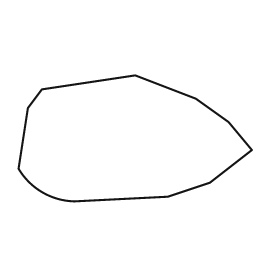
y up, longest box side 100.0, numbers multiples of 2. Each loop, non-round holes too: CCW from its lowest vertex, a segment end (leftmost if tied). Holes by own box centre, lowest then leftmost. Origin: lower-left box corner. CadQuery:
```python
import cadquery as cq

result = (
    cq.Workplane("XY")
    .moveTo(24.0, 0.0)
    .lineTo(64.0, 2.0)
    .lineTo(82.0, 8.0)
    .lineTo(100.0, 22.0)
    .lineTo(90.0, 34.0)
    .lineTo(76.0, 44.0)
    .lineTo(50.0, 54.0)
    .lineTo(10.0, 48.0)
    .lineTo(4.0, 40.0)
    .lineTo(0.0, 14.0)
    .threePointArc((10.0, 4.0), (24.0, 0.0))
    .close()
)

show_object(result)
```